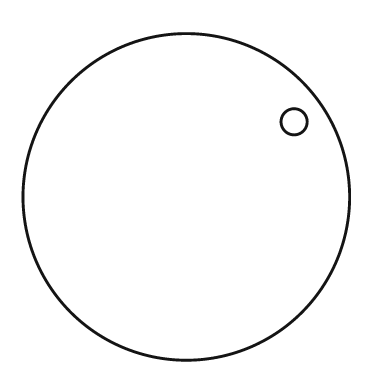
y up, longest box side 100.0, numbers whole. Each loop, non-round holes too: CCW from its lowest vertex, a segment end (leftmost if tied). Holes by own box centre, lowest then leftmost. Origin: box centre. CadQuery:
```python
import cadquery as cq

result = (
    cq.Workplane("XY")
    .moveTo(0.0, 0.0)
    .circle(50.0)
    .moveTo(33.0, 23.0)
    .circle(4.0)
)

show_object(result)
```